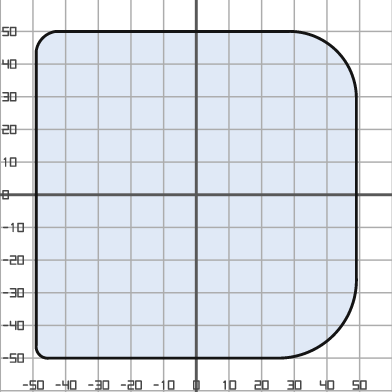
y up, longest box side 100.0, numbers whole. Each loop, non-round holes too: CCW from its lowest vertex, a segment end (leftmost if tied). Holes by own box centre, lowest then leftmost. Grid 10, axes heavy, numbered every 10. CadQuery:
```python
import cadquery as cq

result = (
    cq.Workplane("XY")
    .moveTo(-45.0, -50.0)
    .lineTo(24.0, -50.0)
    .threePointArc((42.0, -43.0), (49.0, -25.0))
    .lineTo(49.0, 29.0)
    .threePointArc((43.0, 44.0), (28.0, 50.0))
    .lineTo(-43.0, 50.0)
    .threePointArc((-47.0, 48.0), (-49.0, 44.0))
    .lineTo(-49.0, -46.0)
    .threePointArc((-48.0, -49.0), (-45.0, -50.0))
    .close()
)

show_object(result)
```